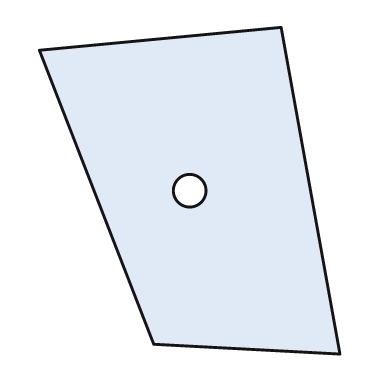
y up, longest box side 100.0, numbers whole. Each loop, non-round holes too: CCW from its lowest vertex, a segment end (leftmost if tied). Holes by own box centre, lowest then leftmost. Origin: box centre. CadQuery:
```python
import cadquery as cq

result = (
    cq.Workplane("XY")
    .moveTo(46.0, -50.0)
    .lineTo(28.0, 50.0)
    .lineTo(-46.0, 43.0)
    .lineTo(-11.0, -47.0)
    .close()
    .moveTo(0.0, 0.0)
    .circle(5.0)
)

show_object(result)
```